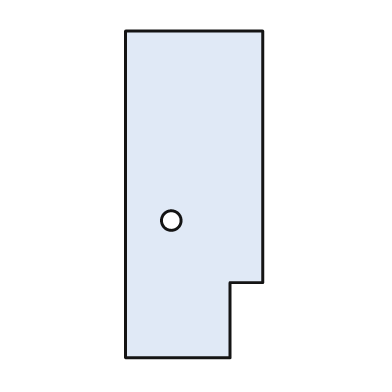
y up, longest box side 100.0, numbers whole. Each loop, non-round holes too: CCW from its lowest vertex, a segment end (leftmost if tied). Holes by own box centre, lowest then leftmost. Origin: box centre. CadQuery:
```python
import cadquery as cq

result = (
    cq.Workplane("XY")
    .moveTo(-21.0, -50.0)
    .lineTo(11.0, -50.0)
    .lineTo(11.0, -27.0)
    .lineTo(21.0, -27.0)
    .lineTo(21.0, 50.0)
    .lineTo(-21.0, 50.0)
    .close()
    .moveTo(-7.0, -8.0)
    .circle(3.0)
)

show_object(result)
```